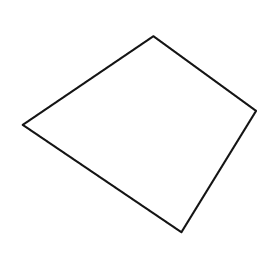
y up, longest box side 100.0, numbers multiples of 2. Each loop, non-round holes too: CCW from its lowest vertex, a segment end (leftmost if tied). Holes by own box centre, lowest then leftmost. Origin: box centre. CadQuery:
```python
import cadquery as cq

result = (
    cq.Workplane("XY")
    .moveTo(18.0, -42.0)
    .lineTo(50.0, 10.0)
    .lineTo(6.0, 42.0)
    .lineTo(-50.0, 4.0)
    .close()
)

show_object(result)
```